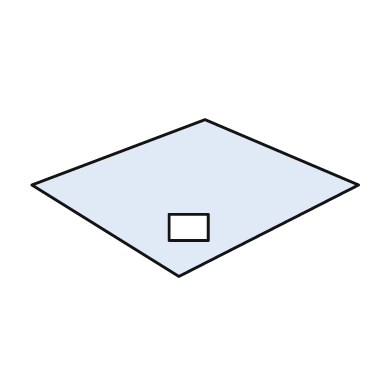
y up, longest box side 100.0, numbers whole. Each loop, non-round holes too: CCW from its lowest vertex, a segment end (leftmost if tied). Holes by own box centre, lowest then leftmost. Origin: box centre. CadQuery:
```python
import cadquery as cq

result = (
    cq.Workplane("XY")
    .moveTo(-5.0, -24.0)
    .lineTo(50.0, 4.0)
    .lineTo(3.0, 24.0)
    .lineTo(-50.0, 4.0)
    .close()
    .moveTo(-8.0, -13.0)
    .lineTo(4.0, -13.0)
    .lineTo(4.0, -5.0)
    .lineTo(-8.0, -5.0)
    .close()
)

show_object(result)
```